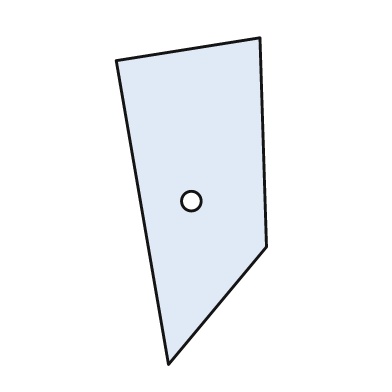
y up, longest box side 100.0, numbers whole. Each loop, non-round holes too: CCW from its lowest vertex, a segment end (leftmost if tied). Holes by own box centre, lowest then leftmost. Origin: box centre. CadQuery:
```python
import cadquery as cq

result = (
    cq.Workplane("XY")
    .moveTo(-7.0, -50.0)
    .lineTo(23.0, -14.0)
    .lineTo(21.0, 50.0)
    .lineTo(-23.0, 43.0)
    .close()
    .moveTo(0.0, 0.0)
    .circle(3.0)
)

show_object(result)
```